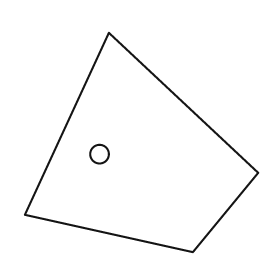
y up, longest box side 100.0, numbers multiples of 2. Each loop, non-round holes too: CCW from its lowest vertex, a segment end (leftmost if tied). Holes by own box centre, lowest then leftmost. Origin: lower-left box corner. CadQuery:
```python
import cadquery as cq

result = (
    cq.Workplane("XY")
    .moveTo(72.0, 0.0)
    .lineTo(100.0, 34.0)
    .lineTo(36.0, 94.0)
    .lineTo(0.0, 16.0)
    .close()
    .moveTo(32.0, 42.0)
    .circle(4.0)
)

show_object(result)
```